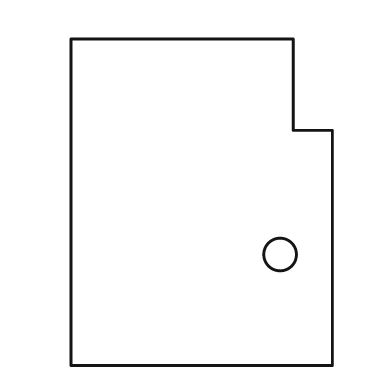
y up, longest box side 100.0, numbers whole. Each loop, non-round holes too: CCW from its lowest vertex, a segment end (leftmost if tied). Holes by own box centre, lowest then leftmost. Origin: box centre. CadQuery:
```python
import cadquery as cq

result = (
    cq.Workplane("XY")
    .moveTo(-40.0, -50.0)
    .lineTo(40.0, -50.0)
    .lineTo(40.0, 22.0)
    .lineTo(28.0, 22.0)
    .lineTo(28.0, 50.0)
    .lineTo(-40.0, 50.0)
    .close()
    .moveTo(24.0, -16.0)
    .circle(5.0)
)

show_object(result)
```